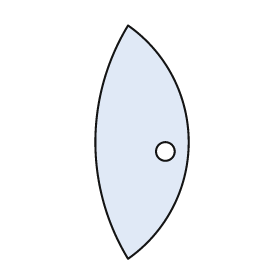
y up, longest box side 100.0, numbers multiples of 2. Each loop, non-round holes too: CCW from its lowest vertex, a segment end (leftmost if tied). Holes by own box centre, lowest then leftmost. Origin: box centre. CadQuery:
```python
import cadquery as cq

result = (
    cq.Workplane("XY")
    .moveTo(-6.0, -50.0)
    .threePointArc((20.0, 0.0), (-6.0, 50.0))
    .threePointArc((-20.0, 0.0), (-6.0, -50.0))
    .close()
    .moveTo(10.0, -4.0)
    .circle(4.0)
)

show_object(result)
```